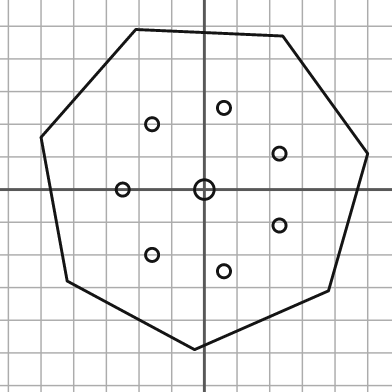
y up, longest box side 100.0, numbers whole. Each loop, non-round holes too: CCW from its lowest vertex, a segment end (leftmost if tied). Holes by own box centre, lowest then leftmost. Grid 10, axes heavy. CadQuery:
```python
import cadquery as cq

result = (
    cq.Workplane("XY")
    .moveTo(-3.0, -49.0)
    .lineTo(38.0, -31.0)
    .lineTo(50.0, 11.0)
    .lineTo(24.0, 47.0)
    .lineTo(-21.0, 49.0)
    .lineTo(-50.0, 16.0)
    .lineTo(-42.0, -28.0)
    .close()
    .moveTo(6.0, -25.0)
    .circle(2.0)
    .moveTo(-16.0, -20.0)
    .circle(2.0)
    .moveTo(23.0, -11.0)
    .circle(2.0)
    .moveTo(-25.0, 0.0)
    .circle(2.0)
    .moveTo(0.0, 0.0)
    .circle(3.0)
    .moveTo(23.0, 11.0)
    .circle(2.0)
    .moveTo(-16.0, 20.0)
    .circle(2.0)
    .moveTo(6.0, 25.0)
    .circle(2.0)
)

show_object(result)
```